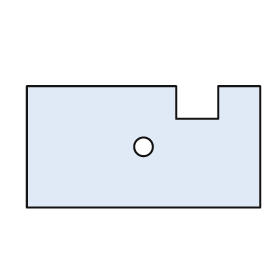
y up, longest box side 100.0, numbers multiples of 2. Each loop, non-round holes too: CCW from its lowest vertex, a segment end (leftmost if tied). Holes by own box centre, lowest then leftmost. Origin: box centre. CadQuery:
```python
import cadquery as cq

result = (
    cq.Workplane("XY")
    .moveTo(-50.0, -26.0)
    .lineTo(50.0, -26.0)
    .lineTo(50.0, 26.0)
    .lineTo(32.0, 26.0)
    .lineTo(32.0, 12.0)
    .lineTo(14.0, 12.0)
    .lineTo(14.0, 26.0)
    .lineTo(-50.0, 26.0)
    .close()
    .moveTo(0.0, 0.0)
    .circle(4.0)
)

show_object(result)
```